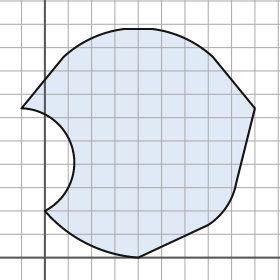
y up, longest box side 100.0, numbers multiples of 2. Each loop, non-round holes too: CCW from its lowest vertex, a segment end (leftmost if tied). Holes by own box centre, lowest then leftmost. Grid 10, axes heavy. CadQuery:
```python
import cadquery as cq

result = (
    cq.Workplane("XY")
    .moveTo(40.0, 0.0)
    .lineTo(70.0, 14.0)
    .threePointArc((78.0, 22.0), (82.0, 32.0))
    .lineTo(90.0, 64.0)
    .lineTo(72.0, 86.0)
    .threePointArc((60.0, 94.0), (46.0, 98.0))
    .lineTo(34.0, 98.0)
    .threePointArc((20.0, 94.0), (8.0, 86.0))
    .lineTo(-10.0, 64.0)
    .threePointArc((12.0, 46.0), (0.0, 20.0))
    .threePointArc((18.0, 6.0), (40.0, 0.0))
    .close()
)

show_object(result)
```